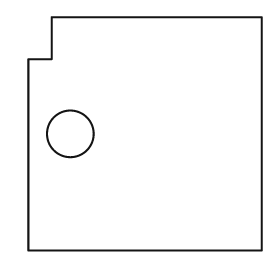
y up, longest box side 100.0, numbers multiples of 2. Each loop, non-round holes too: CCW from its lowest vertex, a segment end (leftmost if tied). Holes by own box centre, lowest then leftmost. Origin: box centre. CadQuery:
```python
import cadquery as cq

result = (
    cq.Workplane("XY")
    .moveTo(-50.0, -50.0)
    .lineTo(50.0, -50.0)
    .lineTo(50.0, 50.0)
    .lineTo(-40.0, 50.0)
    .lineTo(-40.0, 32.0)
    .lineTo(-50.0, 32.0)
    .close()
    .moveTo(-32.0, 0.0)
    .circle(10.0)
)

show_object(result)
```